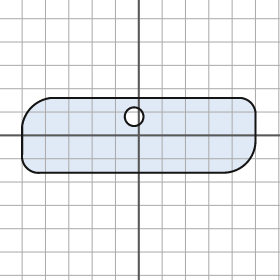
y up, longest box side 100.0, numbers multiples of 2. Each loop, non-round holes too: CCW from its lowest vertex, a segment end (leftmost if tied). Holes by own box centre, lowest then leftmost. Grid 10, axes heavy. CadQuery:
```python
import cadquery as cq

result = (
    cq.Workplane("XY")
    .moveTo(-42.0, -16.0)
    .lineTo(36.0, -16.0)
    .threePointArc((46.0, -12.0), (50.0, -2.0))
    .lineTo(50.0, 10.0)
    .threePointArc((48.0, 14.0), (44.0, 16.0))
    .lineTo(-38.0, 16.0)
    .threePointArc((-46.0, 12.0), (-50.0, 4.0))
    .lineTo(-50.0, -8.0)
    .threePointArc((-48.0, -14.0), (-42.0, -16.0))
    .close()
    .moveTo(-2.0, 8.0)
    .circle(4.0)
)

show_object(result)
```